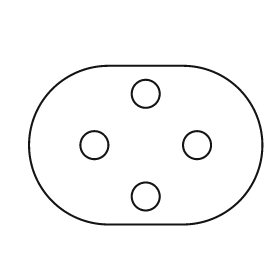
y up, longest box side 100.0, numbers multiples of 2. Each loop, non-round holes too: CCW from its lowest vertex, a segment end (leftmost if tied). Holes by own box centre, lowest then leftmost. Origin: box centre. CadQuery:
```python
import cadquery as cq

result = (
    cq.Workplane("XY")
    .moveTo(-16.0, -34.0)
    .lineTo(16.0, -34.0)
    .threePointArc((50.0, 0.0), (16.0, 34.0))
    .lineTo(-16.0, 34.0)
    .threePointArc((-50.0, 0.0), (-16.0, -34.0))
    .close()
    .moveTo(0.0, -22.0)
    .circle(6.0)
    .moveTo(-22.0, 0.0)
    .circle(6.0)
    .moveTo(22.0, 0.0)
    .circle(6.0)
    .moveTo(0.0, 22.0)
    .circle(6.0)
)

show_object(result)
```